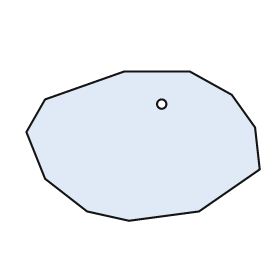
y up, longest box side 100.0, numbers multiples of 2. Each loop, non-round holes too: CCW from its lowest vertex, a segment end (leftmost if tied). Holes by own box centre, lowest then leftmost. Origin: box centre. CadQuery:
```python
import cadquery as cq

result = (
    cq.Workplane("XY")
    .moveTo(-6.0, -32.0)
    .lineTo(24.0, -28.0)
    .lineTo(50.0, -10.0)
    .lineTo(48.0, 8.0)
    .lineTo(38.0, 22.0)
    .lineTo(20.0, 32.0)
    .lineTo(-8.0, 32.0)
    .lineTo(-42.0, 20.0)
    .lineTo(-50.0, 6.0)
    .lineTo(-42.0, -14.0)
    .lineTo(-24.0, -28.0)
    .close()
    .moveTo(8.0, 18.0)
    .circle(2.0)
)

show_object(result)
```